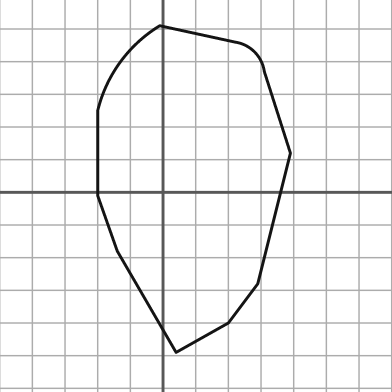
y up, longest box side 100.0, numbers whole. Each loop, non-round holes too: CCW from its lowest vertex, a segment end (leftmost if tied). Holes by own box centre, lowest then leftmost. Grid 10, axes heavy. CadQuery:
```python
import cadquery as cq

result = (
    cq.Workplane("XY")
    .moveTo(4.0, -49.0)
    .lineTo(20.0, -40.0)
    .lineTo(29.0, -28.0)
    .lineTo(39.0, 12.0)
    .lineTo(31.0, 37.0)
    .threePointArc((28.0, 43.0), (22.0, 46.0))
    .lineTo(-1.0, 51.0)
    .threePointArc((-13.0, 40.0), (-20.0, 25.0))
    .lineTo(-20.0, -1.0)
    .lineTo(-14.0, -18.0)
    .close()
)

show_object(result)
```